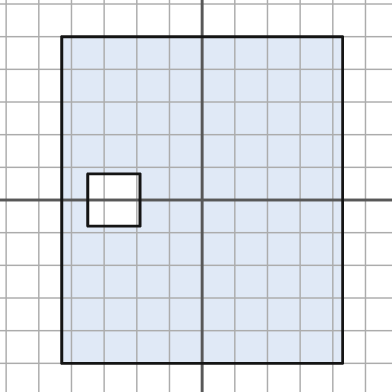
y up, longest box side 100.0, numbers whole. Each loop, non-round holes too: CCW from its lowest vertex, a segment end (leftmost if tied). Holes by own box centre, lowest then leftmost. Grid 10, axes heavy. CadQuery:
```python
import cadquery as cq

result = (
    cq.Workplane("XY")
    .moveTo(-43.0, -50.0)
    .lineTo(43.0, -50.0)
    .lineTo(43.0, 50.0)
    .lineTo(-43.0, 50.0)
    .close()
    .moveTo(-35.0, -8.0)
    .lineTo(-19.0, -8.0)
    .lineTo(-19.0, 8.0)
    .lineTo(-35.0, 8.0)
    .close()
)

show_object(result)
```